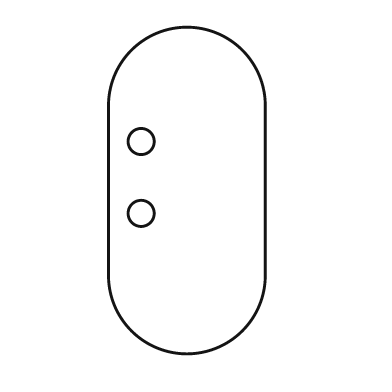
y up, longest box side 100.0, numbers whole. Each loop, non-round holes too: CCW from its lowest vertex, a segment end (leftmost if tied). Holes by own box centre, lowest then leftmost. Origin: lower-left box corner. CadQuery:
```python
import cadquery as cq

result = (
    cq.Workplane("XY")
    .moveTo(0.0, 24.0)
    .threePointArc((24.0, 0.0), (48.0, 24.0))
    .lineTo(48.0, 76.0)
    .threePointArc((24.0, 100.0), (0.0, 76.0))
    .close()
    .moveTo(10.0, 43.0)
    .circle(4.0)
    .moveTo(10.0, 65.0)
    .circle(4.0)
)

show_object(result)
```